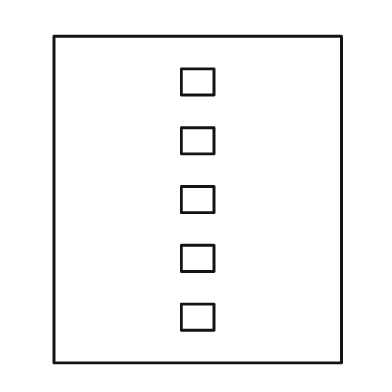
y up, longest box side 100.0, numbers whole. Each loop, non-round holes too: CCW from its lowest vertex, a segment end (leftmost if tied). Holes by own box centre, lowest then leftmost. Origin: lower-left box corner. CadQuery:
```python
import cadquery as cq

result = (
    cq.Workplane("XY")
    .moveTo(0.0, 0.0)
    .lineTo(88.0, 0.0)
    .lineTo(88.0, 100.0)
    .lineTo(0.0, 100.0)
    .close()
    .moveTo(39.0, 10.0)
    .lineTo(49.0, 10.0)
    .lineTo(49.0, 18.0)
    .lineTo(39.0, 18.0)
    .close()
    .moveTo(39.0, 28.0)
    .lineTo(49.0, 28.0)
    .lineTo(49.0, 36.0)
    .lineTo(39.0, 36.0)
    .close()
    .moveTo(39.0, 46.0)
    .lineTo(49.0, 46.0)
    .lineTo(49.0, 54.0)
    .lineTo(39.0, 54.0)
    .close()
    .moveTo(39.0, 64.0)
    .lineTo(49.0, 64.0)
    .lineTo(49.0, 72.0)
    .lineTo(39.0, 72.0)
    .close()
    .moveTo(39.0, 82.0)
    .lineTo(49.0, 82.0)
    .lineTo(49.0, 90.0)
    .lineTo(39.0, 90.0)
    .close()
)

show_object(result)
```